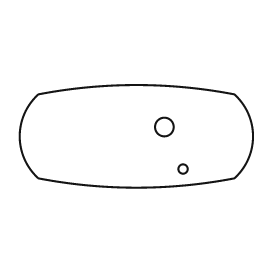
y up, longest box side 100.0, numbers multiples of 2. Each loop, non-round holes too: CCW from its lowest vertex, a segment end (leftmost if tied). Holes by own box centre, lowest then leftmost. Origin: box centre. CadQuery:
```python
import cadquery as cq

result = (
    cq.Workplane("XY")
    .moveTo(-42.0, -18.0)
    .threePointArc((0.0, -22.0), (42.0, -18.0))
    .threePointArc((50.0, 0.0), (42.0, 18.0))
    .threePointArc((0.0, 22.0), (-42.0, 18.0))
    .threePointArc((-50.0, 0.0), (-42.0, -18.0))
    .close()
    .moveTo(20.0, -14.0)
    .circle(2.0)
    .moveTo(12.0, 4.0)
    .circle(4.0)
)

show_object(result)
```